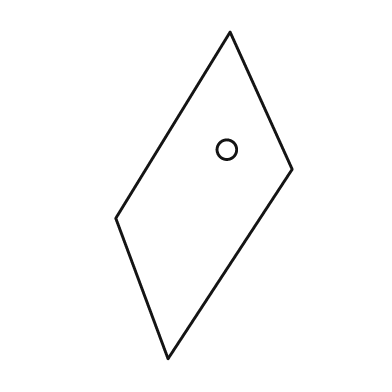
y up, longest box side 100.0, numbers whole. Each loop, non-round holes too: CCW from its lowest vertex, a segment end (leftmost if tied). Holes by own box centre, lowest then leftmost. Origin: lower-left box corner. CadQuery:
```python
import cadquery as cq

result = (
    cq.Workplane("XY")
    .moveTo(16.0, 0.0)
    .lineTo(54.0, 58.0)
    .lineTo(35.0, 100.0)
    .lineTo(0.0, 43.0)
    .close()
    .moveTo(34.0, 64.0)
    .circle(3.0)
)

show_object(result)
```